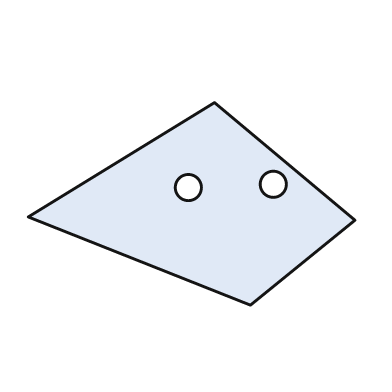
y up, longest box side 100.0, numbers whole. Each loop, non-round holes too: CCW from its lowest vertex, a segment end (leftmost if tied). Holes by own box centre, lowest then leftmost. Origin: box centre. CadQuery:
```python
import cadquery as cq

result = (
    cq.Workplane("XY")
    .moveTo(18.0, -31.0)
    .lineTo(50.0, -5.0)
    .lineTo(7.0, 31.0)
    .lineTo(-50.0, -4.0)
    .close()
    .moveTo(-1.0, 5.0)
    .circle(4.0)
    .moveTo(25.0, 6.0)
    .circle(4.0)
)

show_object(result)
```